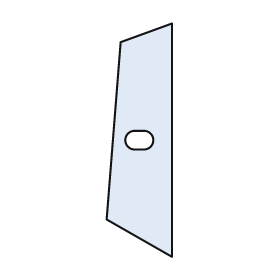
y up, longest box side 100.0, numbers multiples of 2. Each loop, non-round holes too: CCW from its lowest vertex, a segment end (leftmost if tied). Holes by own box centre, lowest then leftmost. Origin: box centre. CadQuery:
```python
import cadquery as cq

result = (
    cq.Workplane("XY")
    .moveTo(14.0, -50.0)
    .lineTo(14.0, 50.0)
    .lineTo(-8.0, 42.0)
    .lineTo(-14.0, -34.0)
    .close()
    .moveTo(-2.0, -4.0)
    .lineTo(2.0, -4.0)
    .threePointArc((6.0, 0.0), (2.0, 4.0))
    .lineTo(-2.0, 4.0)
    .threePointArc((-6.0, 0.0), (-2.0, -4.0))
    .close()
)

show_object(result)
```